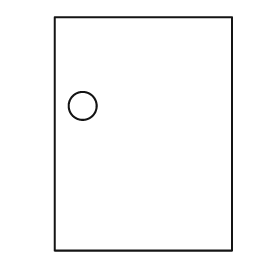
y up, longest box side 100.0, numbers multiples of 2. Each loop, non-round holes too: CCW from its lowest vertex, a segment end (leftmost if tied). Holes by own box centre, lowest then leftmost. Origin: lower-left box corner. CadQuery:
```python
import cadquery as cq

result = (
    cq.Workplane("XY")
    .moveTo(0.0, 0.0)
    .lineTo(76.0, 0.0)
    .lineTo(76.0, 100.0)
    .lineTo(0.0, 100.0)
    .close()
    .moveTo(12.0, 62.0)
    .circle(6.0)
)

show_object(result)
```